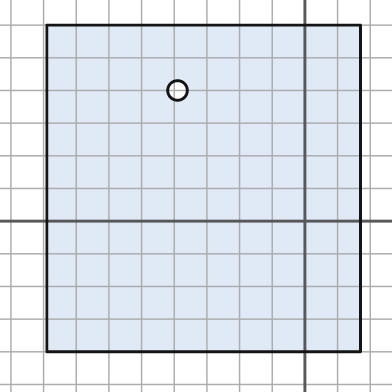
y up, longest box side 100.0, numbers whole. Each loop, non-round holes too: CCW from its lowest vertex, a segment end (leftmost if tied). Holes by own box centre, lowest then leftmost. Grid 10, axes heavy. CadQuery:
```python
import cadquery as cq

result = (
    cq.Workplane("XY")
    .moveTo(-79.0, -40.0)
    .lineTo(17.0, -40.0)
    .lineTo(17.0, 60.0)
    .lineTo(-79.0, 60.0)
    .close()
    .moveTo(-39.0, 40.0)
    .circle(3.0)
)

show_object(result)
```